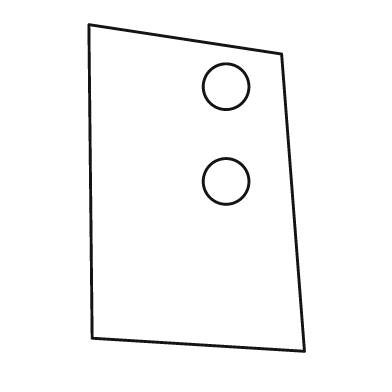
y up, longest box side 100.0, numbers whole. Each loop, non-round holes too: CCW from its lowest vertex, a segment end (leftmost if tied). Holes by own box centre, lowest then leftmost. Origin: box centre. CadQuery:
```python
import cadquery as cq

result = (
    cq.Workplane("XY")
    .moveTo(33.0, -50.0)
    .lineTo(26.0, 41.0)
    .lineTo(-33.0, 50.0)
    .lineTo(-32.0, -46.0)
    .close()
    .moveTo(9.0, 2.0)
    .circle(7.0)
    .moveTo(9.0, 31.0)
    .circle(7.0)
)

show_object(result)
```